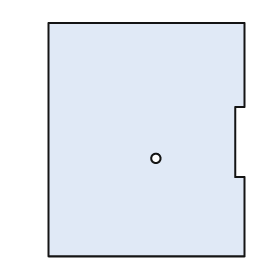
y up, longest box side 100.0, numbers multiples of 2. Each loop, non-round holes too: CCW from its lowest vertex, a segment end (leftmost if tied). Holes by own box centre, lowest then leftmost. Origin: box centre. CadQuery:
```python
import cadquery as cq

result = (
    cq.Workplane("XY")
    .moveTo(-42.0, -50.0)
    .lineTo(42.0, -50.0)
    .lineTo(42.0, -16.0)
    .lineTo(38.0, -16.0)
    .lineTo(38.0, 14.0)
    .lineTo(42.0, 14.0)
    .lineTo(42.0, 50.0)
    .lineTo(-42.0, 50.0)
    .close()
    .moveTo(4.0, -8.0)
    .circle(2.0)
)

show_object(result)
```